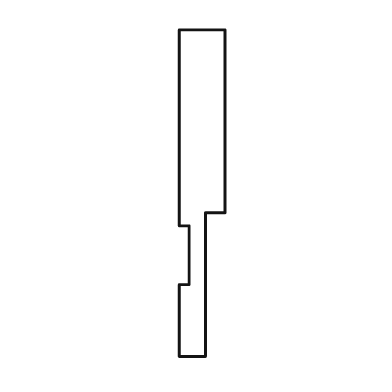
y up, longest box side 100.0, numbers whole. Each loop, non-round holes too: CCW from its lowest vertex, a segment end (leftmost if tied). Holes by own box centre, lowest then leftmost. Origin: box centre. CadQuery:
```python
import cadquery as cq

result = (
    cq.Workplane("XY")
    .moveTo(-7.0, -50.0)
    .lineTo(1.0, -50.0)
    .lineTo(1.0, -6.0)
    .lineTo(7.0, -6.0)
    .lineTo(7.0, 50.0)
    .lineTo(-7.0, 50.0)
    .lineTo(-7.0, -10.0)
    .lineTo(-4.0, -10.0)
    .lineTo(-4.0, -28.0)
    .lineTo(-7.0, -28.0)
    .close()
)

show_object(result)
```